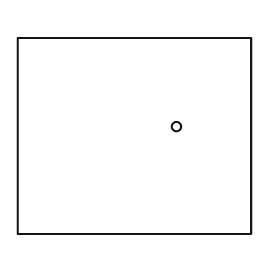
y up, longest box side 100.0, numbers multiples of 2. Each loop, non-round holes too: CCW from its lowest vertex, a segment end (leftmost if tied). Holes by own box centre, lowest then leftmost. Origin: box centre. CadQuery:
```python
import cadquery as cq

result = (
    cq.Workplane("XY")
    .moveTo(-50.0, -42.0)
    .lineTo(50.0, -42.0)
    .lineTo(50.0, 42.0)
    .lineTo(-50.0, 42.0)
    .close()
    .moveTo(18.0, 4.0)
    .circle(2.0)
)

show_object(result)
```